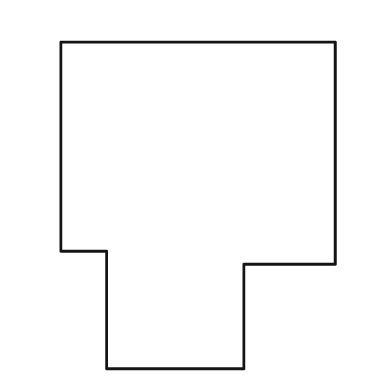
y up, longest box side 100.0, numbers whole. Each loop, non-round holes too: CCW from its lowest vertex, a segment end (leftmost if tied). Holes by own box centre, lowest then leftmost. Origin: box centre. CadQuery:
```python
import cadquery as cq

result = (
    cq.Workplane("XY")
    .moveTo(-28.0, -50.0)
    .lineTo(14.0, -50.0)
    .lineTo(14.0, -18.0)
    .lineTo(42.0, -18.0)
    .lineTo(42.0, 50.0)
    .lineTo(-42.0, 50.0)
    .lineTo(-42.0, -14.0)
    .lineTo(-28.0, -14.0)
    .close()
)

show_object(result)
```